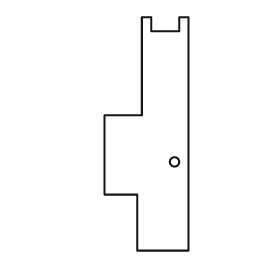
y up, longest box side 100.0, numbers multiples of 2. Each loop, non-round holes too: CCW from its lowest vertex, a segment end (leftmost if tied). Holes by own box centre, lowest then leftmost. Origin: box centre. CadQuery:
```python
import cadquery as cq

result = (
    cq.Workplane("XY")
    .moveTo(-4.0, -50.0)
    .lineTo(18.0, -50.0)
    .lineTo(18.0, 50.0)
    .lineTo(14.0, 50.0)
    .lineTo(14.0, 44.0)
    .lineTo(2.0, 44.0)
    .lineTo(2.0, 50.0)
    .lineTo(-2.0, 50.0)
    .lineTo(-2.0, 8.0)
    .lineTo(-18.0, 8.0)
    .lineTo(-18.0, -26.0)
    .lineTo(-4.0, -26.0)
    .close()
    .moveTo(12.0, -12.0)
    .circle(2.0)
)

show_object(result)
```